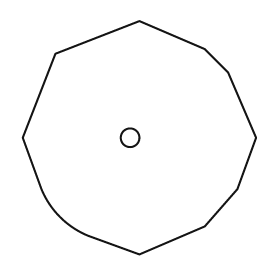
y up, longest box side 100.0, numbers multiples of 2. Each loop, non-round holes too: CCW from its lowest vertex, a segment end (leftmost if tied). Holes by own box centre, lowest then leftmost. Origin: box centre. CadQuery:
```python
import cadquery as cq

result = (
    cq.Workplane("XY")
    .moveTo(0.0, -50.0)
    .lineTo(28.0, -38.0)
    .lineTo(42.0, -22.0)
    .lineTo(50.0, 0.0)
    .lineTo(38.0, 28.0)
    .lineTo(28.0, 38.0)
    .lineTo(0.0, 50.0)
    .lineTo(-36.0, 36.0)
    .lineTo(-50.0, 0.0)
    .lineTo(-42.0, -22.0)
    .threePointArc((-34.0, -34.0), (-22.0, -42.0))
    .close()
    .moveTo(-4.0, 0.0)
    .circle(4.0)
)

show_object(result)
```